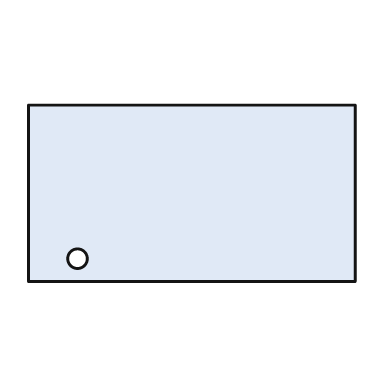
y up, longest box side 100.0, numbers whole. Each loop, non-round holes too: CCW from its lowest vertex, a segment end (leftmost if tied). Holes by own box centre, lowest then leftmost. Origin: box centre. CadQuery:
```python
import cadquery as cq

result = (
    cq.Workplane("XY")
    .moveTo(-50.0, -27.0)
    .lineTo(50.0, -27.0)
    .lineTo(50.0, 27.0)
    .lineTo(-50.0, 27.0)
    .close()
    .moveTo(-35.0, -20.0)
    .circle(3.0)
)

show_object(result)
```